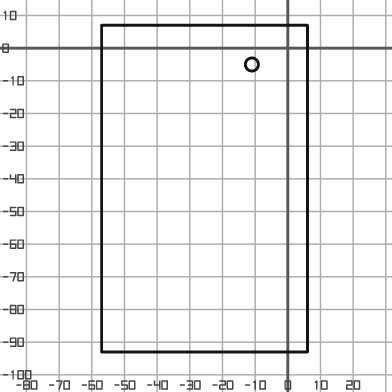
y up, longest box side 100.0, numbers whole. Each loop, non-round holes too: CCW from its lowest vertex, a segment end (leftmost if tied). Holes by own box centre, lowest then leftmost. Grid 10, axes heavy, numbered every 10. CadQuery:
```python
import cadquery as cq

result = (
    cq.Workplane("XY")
    .moveTo(-57.0, -93.0)
    .lineTo(6.0, -93.0)
    .lineTo(6.0, 7.0)
    .lineTo(-57.0, 7.0)
    .close()
    .moveTo(-11.0, -5.0)
    .circle(2.0)
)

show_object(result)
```